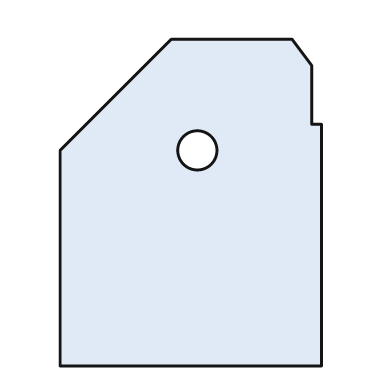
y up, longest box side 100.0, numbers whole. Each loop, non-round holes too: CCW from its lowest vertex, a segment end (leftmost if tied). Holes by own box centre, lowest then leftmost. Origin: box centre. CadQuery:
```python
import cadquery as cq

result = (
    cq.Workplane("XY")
    .moveTo(-40.0, -50.0)
    .lineTo(40.0, -50.0)
    .lineTo(40.0, 24.0)
    .lineTo(37.0, 24.0)
    .lineTo(37.0, 42.0)
    .lineTo(31.0, 50.0)
    .lineTo(-6.0, 50.0)
    .lineTo(-40.0, 16.0)
    .close()
    .moveTo(2.0, 16.0)
    .circle(6.0)
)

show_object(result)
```